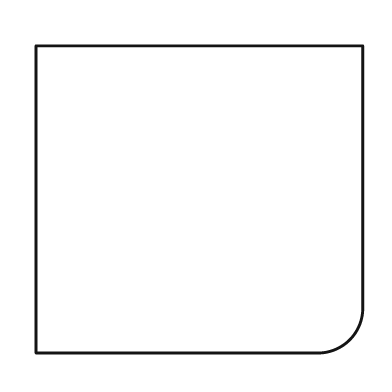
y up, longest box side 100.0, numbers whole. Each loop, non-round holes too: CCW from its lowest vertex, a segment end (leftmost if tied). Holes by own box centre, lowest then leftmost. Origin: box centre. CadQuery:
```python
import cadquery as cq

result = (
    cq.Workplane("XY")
    .moveTo(-50.0, -47.0)
    .lineTo(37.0, -47.0)
    .threePointArc((46.0, -43.0), (50.0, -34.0))
    .lineTo(50.0, 47.0)
    .lineTo(-50.0, 47.0)
    .close()
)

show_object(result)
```